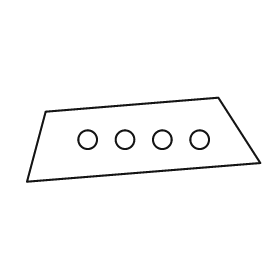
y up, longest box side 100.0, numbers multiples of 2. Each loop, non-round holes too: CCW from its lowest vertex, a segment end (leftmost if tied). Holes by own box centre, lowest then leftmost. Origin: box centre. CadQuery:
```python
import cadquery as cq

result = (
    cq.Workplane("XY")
    .moveTo(-50.0, -18.0)
    .lineTo(50.0, -10.0)
    .lineTo(32.0, 18.0)
    .lineTo(-42.0, 12.0)
    .close()
    .moveTo(-24.0, 0.0)
    .circle(4.0)
    .moveTo(-8.0, 0.0)
    .circle(4.0)
    .moveTo(8.0, 0.0)
    .circle(4.0)
    .moveTo(24.0, 0.0)
    .circle(4.0)
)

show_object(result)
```